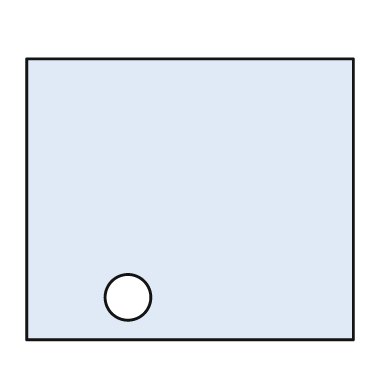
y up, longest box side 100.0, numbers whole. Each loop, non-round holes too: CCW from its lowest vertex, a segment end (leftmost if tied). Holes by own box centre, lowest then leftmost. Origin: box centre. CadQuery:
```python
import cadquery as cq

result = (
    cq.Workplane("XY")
    .moveTo(-50.0, -43.0)
    .lineTo(50.0, -43.0)
    .lineTo(50.0, 43.0)
    .lineTo(-50.0, 43.0)
    .close()
    .moveTo(-19.0, -30.0)
    .circle(7.0)
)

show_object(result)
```